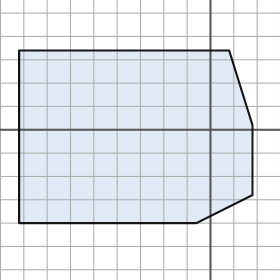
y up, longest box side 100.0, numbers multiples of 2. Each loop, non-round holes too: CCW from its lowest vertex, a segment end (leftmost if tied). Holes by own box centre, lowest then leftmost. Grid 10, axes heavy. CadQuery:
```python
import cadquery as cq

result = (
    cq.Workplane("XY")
    .moveTo(-82.0, -40.0)
    .lineTo(-6.0, -40.0)
    .lineTo(18.0, -28.0)
    .lineTo(18.0, 2.0)
    .lineTo(8.0, 34.0)
    .lineTo(-82.0, 34.0)
    .close()
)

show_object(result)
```